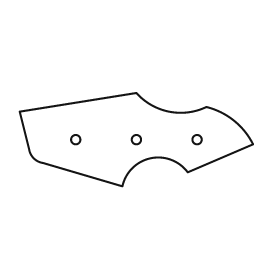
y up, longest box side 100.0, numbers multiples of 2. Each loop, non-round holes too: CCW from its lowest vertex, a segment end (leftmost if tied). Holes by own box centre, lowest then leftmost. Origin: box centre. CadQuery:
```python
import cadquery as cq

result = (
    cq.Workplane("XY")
    .moveTo(-6.0, -20.0)
    .threePointArc((6.0, -8.0), (22.0, -14.0))
    .lineTo(50.0, -2.0)
    .threePointArc((42.0, 8.0), (30.0, 14.0))
    .threePointArc((14.0, 12.0), (0.0, 20.0))
    .lineTo(-50.0, 12.0)
    .lineTo(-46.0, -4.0)
    .threePointArc((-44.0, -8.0), (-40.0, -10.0))
    .close()
    .moveTo(-26.0, 0.0)
    .circle(2.0)
    .moveTo(0.0, 0.0)
    .circle(2.0)
    .moveTo(26.0, 0.0)
    .circle(2.0)
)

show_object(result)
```